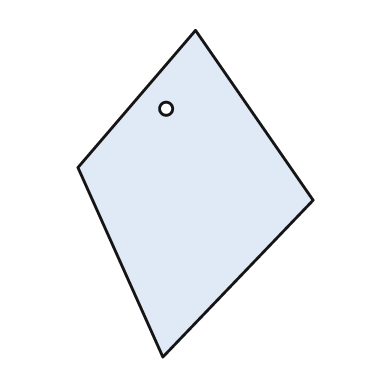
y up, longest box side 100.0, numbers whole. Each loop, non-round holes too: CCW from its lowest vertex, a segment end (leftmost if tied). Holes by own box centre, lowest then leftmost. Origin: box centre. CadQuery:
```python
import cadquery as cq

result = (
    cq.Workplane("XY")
    .moveTo(-10.0, -50.0)
    .lineTo(36.0, -2.0)
    .lineTo(0.0, 50.0)
    .lineTo(-36.0, 8.0)
    .close()
    .moveTo(-9.0, 26.0)
    .circle(2.0)
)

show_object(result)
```